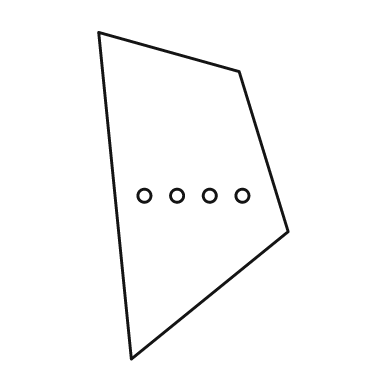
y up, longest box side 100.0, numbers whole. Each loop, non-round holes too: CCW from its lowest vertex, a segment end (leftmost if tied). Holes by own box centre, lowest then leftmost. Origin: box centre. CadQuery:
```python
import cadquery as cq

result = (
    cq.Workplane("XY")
    .moveTo(-19.0, -50.0)
    .lineTo(29.0, -11.0)
    .lineTo(14.0, 38.0)
    .lineTo(-29.0, 50.0)
    .close()
    .moveTo(-15.0, 0.0)
    .circle(2.0)
    .moveTo(-5.0, 0.0)
    .circle(2.0)
    .moveTo(5.0, 0.0)
    .circle(2.0)
    .moveTo(15.0, 0.0)
    .circle(2.0)
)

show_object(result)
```